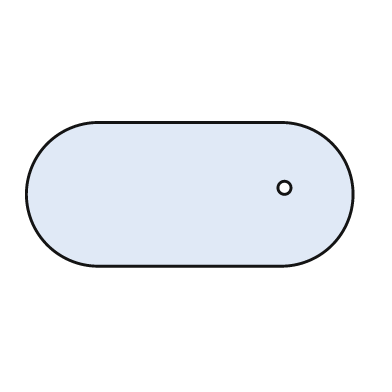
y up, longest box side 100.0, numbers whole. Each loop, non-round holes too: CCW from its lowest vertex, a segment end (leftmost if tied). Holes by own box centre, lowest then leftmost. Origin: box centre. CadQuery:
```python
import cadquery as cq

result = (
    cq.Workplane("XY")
    .moveTo(-28.0, -22.0)
    .lineTo(28.0, -22.0)
    .threePointArc((50.0, 0.0), (28.0, 22.0))
    .lineTo(-28.0, 22.0)
    .threePointArc((-50.0, 0.0), (-28.0, -22.0))
    .close()
    .moveTo(29.0, 2.0)
    .circle(2.0)
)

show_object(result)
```